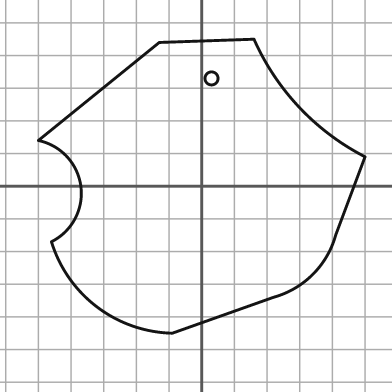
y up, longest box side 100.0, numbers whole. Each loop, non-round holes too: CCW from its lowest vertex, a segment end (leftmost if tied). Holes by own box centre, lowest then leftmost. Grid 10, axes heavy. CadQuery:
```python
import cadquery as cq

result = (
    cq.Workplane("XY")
    .moveTo(-9.0, -45.0)
    .lineTo(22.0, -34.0)
    .threePointArc((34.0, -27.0), (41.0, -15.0))
    .lineTo(50.0, 9.0)
    .threePointArc((30.0, 24.0), (16.0, 45.0))
    .lineTo(-13.0, 44.0)
    .lineTo(-50.0, 14.0)
    .threePointArc((-37.0, 0.0), (-46.0, -17.0))
    .threePointArc((-32.0, -37.0), (-9.0, -45.0))
    .close()
    .moveTo(3.0, 33.0)
    .circle(2.0)
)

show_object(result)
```